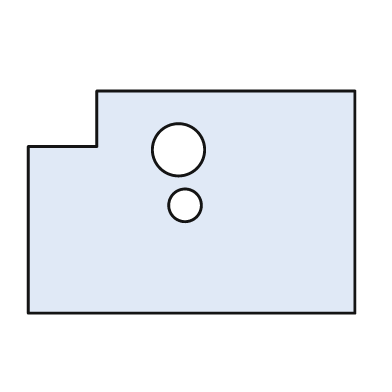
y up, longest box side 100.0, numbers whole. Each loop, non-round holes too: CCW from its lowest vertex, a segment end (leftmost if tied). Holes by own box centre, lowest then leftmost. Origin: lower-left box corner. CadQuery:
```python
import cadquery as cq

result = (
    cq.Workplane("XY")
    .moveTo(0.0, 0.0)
    .lineTo(100.0, 0.0)
    .lineTo(100.0, 68.0)
    .lineTo(21.0, 68.0)
    .lineTo(21.0, 51.0)
    .lineTo(0.0, 51.0)
    .close()
    .moveTo(48.0, 33.0)
    .circle(5.0)
    .moveTo(46.0, 50.0)
    .circle(8.0)
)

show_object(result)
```